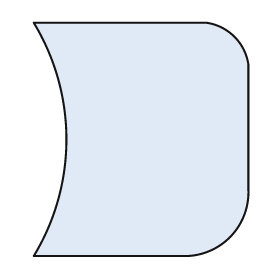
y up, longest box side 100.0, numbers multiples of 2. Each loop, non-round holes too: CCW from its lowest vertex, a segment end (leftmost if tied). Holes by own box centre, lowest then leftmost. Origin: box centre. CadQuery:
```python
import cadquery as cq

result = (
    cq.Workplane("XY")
    .moveTo(-46.0, -50.0)
    .lineTo(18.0, -50.0)
    .threePointArc((38.0, -42.0), (46.0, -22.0))
    .lineTo(46.0, 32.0)
    .threePointArc((40.0, 44.0), (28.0, 50.0))
    .lineTo(-46.0, 50.0)
    .threePointArc((-32.0, 0.0), (-46.0, -50.0))
    .close()
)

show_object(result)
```